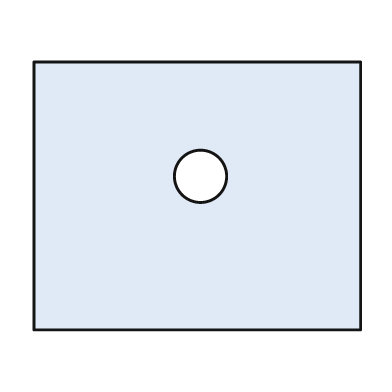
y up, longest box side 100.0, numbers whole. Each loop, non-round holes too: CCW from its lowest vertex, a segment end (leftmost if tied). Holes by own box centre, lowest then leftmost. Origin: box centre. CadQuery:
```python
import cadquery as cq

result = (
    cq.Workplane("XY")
    .moveTo(-50.0, -41.0)
    .lineTo(50.0, -41.0)
    .lineTo(50.0, 41.0)
    .lineTo(-50.0, 41.0)
    .close()
    .moveTo(1.0, 6.0)
    .circle(8.0)
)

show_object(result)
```